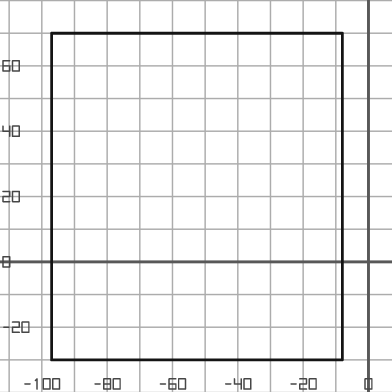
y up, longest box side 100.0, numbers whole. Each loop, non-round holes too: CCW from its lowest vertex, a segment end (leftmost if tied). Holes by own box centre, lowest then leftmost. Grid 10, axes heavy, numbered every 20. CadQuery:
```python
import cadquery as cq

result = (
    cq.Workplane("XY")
    .moveTo(-97.0, -30.0)
    .lineTo(-8.0, -30.0)
    .lineTo(-8.0, 70.0)
    .lineTo(-97.0, 70.0)
    .close()
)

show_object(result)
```